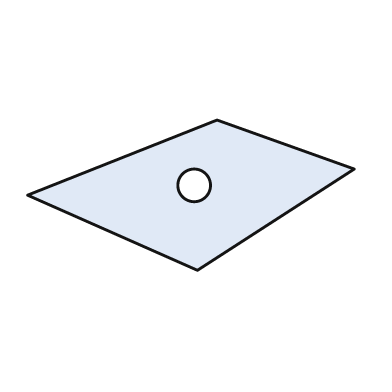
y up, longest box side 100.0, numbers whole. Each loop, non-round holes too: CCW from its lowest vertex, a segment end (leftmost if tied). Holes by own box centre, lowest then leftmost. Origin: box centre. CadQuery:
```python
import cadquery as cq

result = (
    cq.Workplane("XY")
    .moveTo(2.0, -23.0)
    .lineTo(50.0, 8.0)
    .lineTo(8.0, 23.0)
    .lineTo(-50.0, 0.0)
    .close()
    .moveTo(1.0, 3.0)
    .circle(5.0)
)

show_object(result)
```